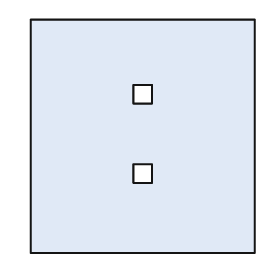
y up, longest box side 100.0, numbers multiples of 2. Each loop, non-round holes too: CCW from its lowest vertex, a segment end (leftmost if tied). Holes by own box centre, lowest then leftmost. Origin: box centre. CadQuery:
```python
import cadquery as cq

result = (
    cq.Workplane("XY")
    .moveTo(-48.0, -50.0)
    .lineTo(48.0, -50.0)
    .lineTo(48.0, 50.0)
    .lineTo(-48.0, 50.0)
    .close()
    .moveTo(-4.0, -20.0)
    .lineTo(4.0, -20.0)
    .lineTo(4.0, -12.0)
    .lineTo(-4.0, -12.0)
    .close()
    .moveTo(-4.0, 14.0)
    .lineTo(4.0, 14.0)
    .lineTo(4.0, 22.0)
    .lineTo(-4.0, 22.0)
    .close()
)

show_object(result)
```